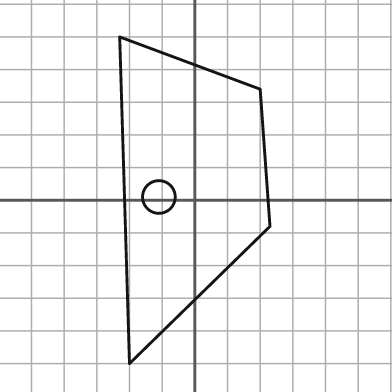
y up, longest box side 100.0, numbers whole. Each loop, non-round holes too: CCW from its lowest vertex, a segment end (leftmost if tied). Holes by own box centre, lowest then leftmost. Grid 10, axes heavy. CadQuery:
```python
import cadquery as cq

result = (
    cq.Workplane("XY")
    .moveTo(-20.0, -50.0)
    .lineTo(23.0, -8.0)
    .lineTo(20.0, 34.0)
    .lineTo(-23.0, 50.0)
    .close()
    .moveTo(-11.0, 1.0)
    .circle(5.0)
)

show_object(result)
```